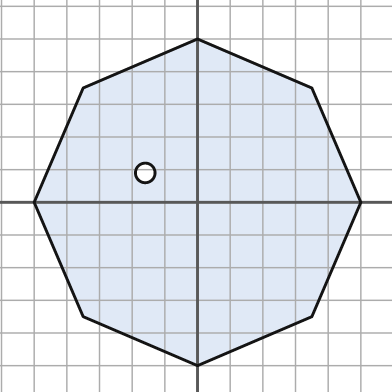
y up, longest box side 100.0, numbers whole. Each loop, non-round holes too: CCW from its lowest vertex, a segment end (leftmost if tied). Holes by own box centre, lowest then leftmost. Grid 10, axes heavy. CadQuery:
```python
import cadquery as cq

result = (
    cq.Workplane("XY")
    .moveTo(0.0, -50.0)
    .lineTo(35.0, -35.0)
    .lineTo(50.0, 0.0)
    .lineTo(35.0, 35.0)
    .lineTo(0.0, 50.0)
    .lineTo(-35.0, 35.0)
    .lineTo(-50.0, 0.0)
    .lineTo(-35.0, -35.0)
    .close()
    .moveTo(-16.0, 9.0)
    .circle(3.0)
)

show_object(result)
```